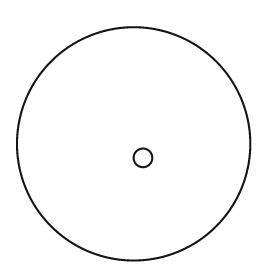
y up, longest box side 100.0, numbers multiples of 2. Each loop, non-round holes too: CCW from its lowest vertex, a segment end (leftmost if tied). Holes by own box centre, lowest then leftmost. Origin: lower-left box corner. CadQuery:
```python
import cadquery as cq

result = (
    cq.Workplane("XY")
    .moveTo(50.0, 50.0)
    .circle(50.0)
    .moveTo(54.0, 44.0)
    .circle(4.0)
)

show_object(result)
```